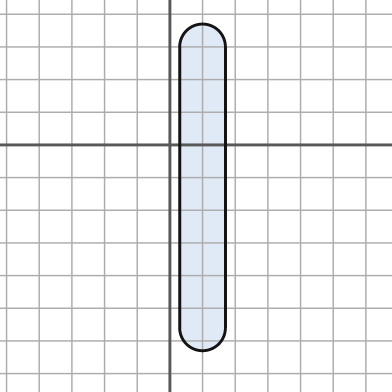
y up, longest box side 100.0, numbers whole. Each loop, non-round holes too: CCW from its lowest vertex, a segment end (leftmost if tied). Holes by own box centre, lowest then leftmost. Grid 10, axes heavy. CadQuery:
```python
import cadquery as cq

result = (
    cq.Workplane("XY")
    .moveTo(3.0, -56.0)
    .threePointArc((10.0, -63.0), (17.0, -56.0))
    .lineTo(17.0, 30.0)
    .threePointArc((10.0, 37.0), (3.0, 30.0))
    .close()
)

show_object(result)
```